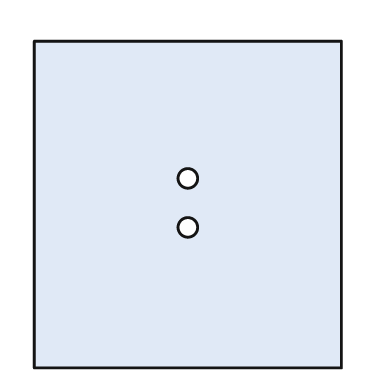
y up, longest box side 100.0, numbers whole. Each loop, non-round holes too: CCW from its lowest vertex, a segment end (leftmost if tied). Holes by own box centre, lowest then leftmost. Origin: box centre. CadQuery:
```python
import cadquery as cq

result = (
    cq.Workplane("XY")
    .moveTo(-47.0, -50.0)
    .lineTo(47.0, -50.0)
    .lineTo(47.0, 50.0)
    .lineTo(-47.0, 50.0)
    .close()
    .moveTo(0.0, -7.0)
    .circle(3.0)
    .moveTo(0.0, 8.0)
    .circle(3.0)
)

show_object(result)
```